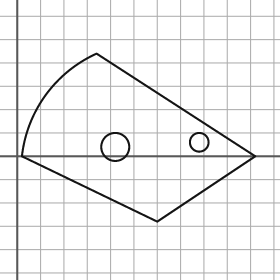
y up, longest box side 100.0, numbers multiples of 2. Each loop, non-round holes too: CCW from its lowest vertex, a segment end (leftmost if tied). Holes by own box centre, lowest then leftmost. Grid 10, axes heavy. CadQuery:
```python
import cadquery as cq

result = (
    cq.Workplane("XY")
    .moveTo(60.0, -28.0)
    .lineTo(102.0, 0.0)
    .lineTo(34.0, 44.0)
    .threePointArc((12.0, 26.0), (2.0, 0.0))
    .close()
    .moveTo(42.0, 4.0)
    .circle(6.0)
    .moveTo(78.0, 6.0)
    .circle(4.0)
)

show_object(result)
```